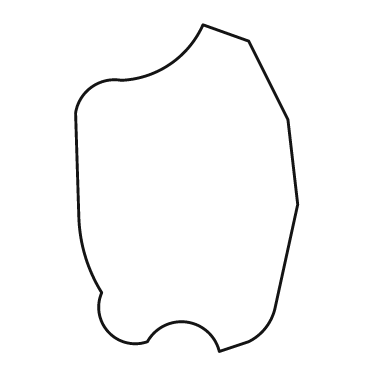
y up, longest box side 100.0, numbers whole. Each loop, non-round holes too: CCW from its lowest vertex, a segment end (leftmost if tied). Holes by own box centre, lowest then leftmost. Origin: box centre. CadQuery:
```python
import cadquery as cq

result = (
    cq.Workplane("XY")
    .moveTo(10.0, -50.0)
    .lineTo(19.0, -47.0)
    .threePointArc((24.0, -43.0), (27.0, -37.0))
    .lineTo(34.0, -5.0)
    .lineTo(31.0, 21.0)
    .lineTo(19.0, 45.0)
    .lineTo(5.0, 50.0)
    .threePointArc((-5.0, 38.0), (-20.0, 33.0))
    .threePointArc((-29.0, 31.0), (-34.0, 23.0))
    .lineTo(-33.0, -9.0)
    .threePointArc((-31.0, -21.0), (-26.0, -32.0))
    .threePointArc((-24.0, -44.0), (-12.0, -47.0))
    .threePointArc((0.0, -41.0), (10.0, -50.0))
    .close()
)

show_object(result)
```